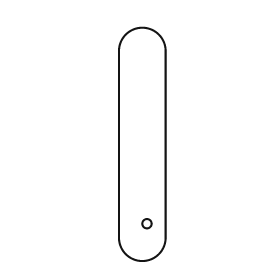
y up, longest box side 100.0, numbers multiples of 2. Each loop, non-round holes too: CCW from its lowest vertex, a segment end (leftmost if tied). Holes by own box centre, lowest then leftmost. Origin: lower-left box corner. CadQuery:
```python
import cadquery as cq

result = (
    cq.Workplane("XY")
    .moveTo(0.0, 10.0)
    .threePointArc((10.0, 0.0), (20.0, 10.0))
    .lineTo(20.0, 90.0)
    .threePointArc((10.0, 100.0), (0.0, 90.0))
    .close()
    .moveTo(12.0, 16.0)
    .circle(2.0)
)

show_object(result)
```